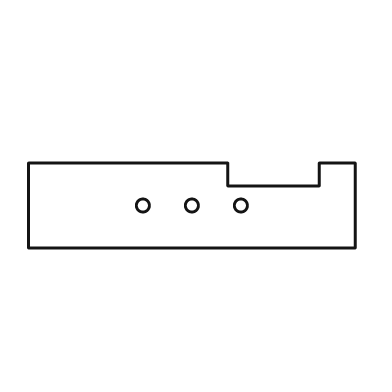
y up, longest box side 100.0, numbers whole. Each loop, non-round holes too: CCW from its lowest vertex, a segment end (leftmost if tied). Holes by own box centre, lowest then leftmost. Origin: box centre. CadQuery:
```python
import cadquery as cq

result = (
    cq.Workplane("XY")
    .moveTo(-50.0, -13.0)
    .lineTo(50.0, -13.0)
    .lineTo(50.0, 13.0)
    .lineTo(39.0, 13.0)
    .lineTo(39.0, 6.0)
    .lineTo(11.0, 6.0)
    .lineTo(11.0, 13.0)
    .lineTo(-50.0, 13.0)
    .close()
    .moveTo(-15.0, 0.0)
    .circle(2.0)
    .moveTo(0.0, 0.0)
    .circle(2.0)
    .moveTo(15.0, 0.0)
    .circle(2.0)
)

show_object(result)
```